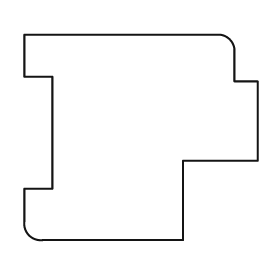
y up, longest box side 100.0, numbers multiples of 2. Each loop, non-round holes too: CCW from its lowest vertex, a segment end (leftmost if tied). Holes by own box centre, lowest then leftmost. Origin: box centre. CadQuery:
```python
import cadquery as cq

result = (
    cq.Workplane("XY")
    .moveTo(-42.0, -44.0)
    .lineTo(18.0, -44.0)
    .lineTo(18.0, -10.0)
    .lineTo(50.0, -10.0)
    .lineTo(50.0, 24.0)
    .lineTo(40.0, 24.0)
    .lineTo(40.0, 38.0)
    .threePointArc((38.0, 42.0), (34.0, 44.0))
    .lineTo(-50.0, 44.0)
    .lineTo(-50.0, 26.0)
    .lineTo(-38.0, 26.0)
    .lineTo(-38.0, -22.0)
    .lineTo(-50.0, -22.0)
    .lineTo(-50.0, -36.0)
    .threePointArc((-48.0, -42.0), (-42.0, -44.0))
    .close()
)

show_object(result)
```